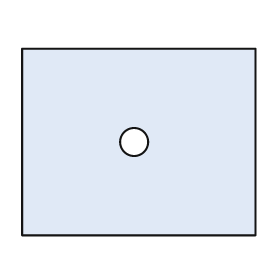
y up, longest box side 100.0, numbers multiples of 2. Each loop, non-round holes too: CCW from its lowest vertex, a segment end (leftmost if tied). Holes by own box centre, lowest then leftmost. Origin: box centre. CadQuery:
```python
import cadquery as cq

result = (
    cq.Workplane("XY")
    .moveTo(-50.0, -40.0)
    .lineTo(50.0, -40.0)
    .lineTo(50.0, 40.0)
    .lineTo(-50.0, 40.0)
    .close()
    .moveTo(-2.0, 0.0)
    .circle(6.0)
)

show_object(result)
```